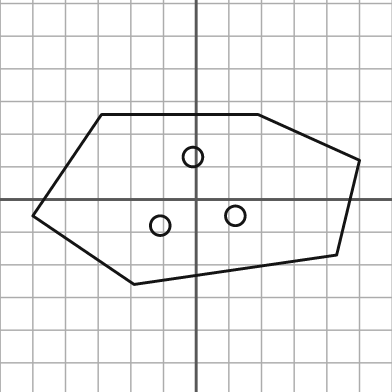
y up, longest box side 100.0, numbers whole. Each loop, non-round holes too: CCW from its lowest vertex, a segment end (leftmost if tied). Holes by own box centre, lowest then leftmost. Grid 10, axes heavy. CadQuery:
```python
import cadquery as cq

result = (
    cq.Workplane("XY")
    .moveTo(-19.0, -26.0)
    .lineTo(43.0, -17.0)
    .lineTo(50.0, 12.0)
    .lineTo(19.0, 26.0)
    .lineTo(-29.0, 26.0)
    .lineTo(-50.0, -5.0)
    .close()
    .moveTo(-11.0, -8.0)
    .circle(3.0)
    .moveTo(12.0, -5.0)
    .circle(3.0)
    .moveTo(-1.0, 13.0)
    .circle(3.0)
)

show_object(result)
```